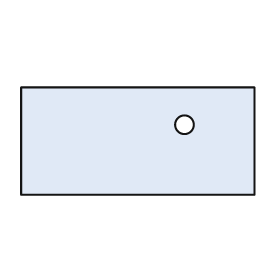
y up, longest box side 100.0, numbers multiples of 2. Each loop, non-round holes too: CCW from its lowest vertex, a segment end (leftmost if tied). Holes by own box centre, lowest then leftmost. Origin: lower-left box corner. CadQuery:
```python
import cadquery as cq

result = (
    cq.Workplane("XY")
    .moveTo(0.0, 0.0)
    .lineTo(100.0, 0.0)
    .lineTo(100.0, 46.0)
    .lineTo(0.0, 46.0)
    .close()
    .moveTo(70.0, 30.0)
    .circle(4.0)
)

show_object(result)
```